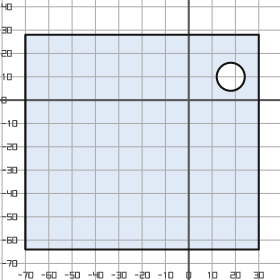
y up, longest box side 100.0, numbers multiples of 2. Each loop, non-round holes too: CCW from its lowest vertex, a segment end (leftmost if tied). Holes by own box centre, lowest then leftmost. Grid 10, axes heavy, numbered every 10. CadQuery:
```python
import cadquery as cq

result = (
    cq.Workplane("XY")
    .moveTo(-70.0, -64.0)
    .lineTo(30.0, -64.0)
    .lineTo(30.0, 28.0)
    .lineTo(-70.0, 28.0)
    .close()
    .moveTo(18.0, 10.0)
    .circle(6.0)
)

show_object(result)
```